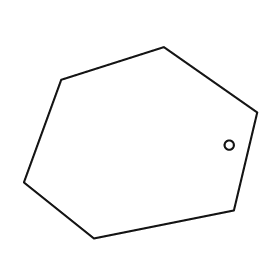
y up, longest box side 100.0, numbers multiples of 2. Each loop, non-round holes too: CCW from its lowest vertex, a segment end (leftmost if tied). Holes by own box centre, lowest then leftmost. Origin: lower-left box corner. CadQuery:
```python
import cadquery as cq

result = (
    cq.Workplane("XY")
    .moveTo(30.0, 0.0)
    .lineTo(90.0, 12.0)
    .lineTo(100.0, 54.0)
    .lineTo(60.0, 82.0)
    .lineTo(16.0, 68.0)
    .lineTo(0.0, 24.0)
    .close()
    .moveTo(88.0, 40.0)
    .circle(2.0)
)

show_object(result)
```